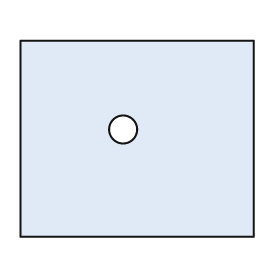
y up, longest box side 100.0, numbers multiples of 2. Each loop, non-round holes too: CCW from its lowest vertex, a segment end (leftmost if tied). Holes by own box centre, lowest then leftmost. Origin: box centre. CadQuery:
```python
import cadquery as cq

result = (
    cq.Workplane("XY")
    .moveTo(-50.0, -42.0)
    .lineTo(50.0, -42.0)
    .lineTo(50.0, 42.0)
    .lineTo(-50.0, 42.0)
    .close()
    .moveTo(-6.0, 4.0)
    .circle(6.0)
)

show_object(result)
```